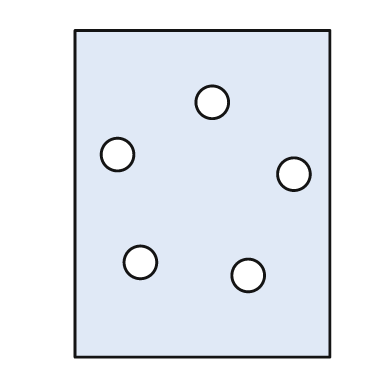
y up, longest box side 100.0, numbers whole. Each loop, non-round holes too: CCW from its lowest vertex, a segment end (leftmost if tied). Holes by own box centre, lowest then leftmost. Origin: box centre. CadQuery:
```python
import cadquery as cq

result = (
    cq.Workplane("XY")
    .moveTo(-39.0, -50.0)
    .lineTo(39.0, -50.0)
    .lineTo(39.0, 50.0)
    .lineTo(-39.0, 50.0)
    .close()
    .moveTo(14.0, -25.0)
    .circle(5.0)
    .moveTo(-19.0, -21.0)
    .circle(5.0)
    .moveTo(28.0, 6.0)
    .circle(5.0)
    .moveTo(-26.0, 12.0)
    .circle(5.0)
    .moveTo(3.0, 28.0)
    .circle(5.0)
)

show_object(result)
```